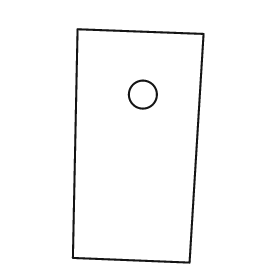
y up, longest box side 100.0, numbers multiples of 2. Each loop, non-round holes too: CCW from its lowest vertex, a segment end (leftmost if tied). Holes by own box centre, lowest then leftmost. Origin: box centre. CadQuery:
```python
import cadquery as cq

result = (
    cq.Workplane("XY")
    .moveTo(22.0, -50.0)
    .lineTo(28.0, 48.0)
    .lineTo(-26.0, 50.0)
    .lineTo(-28.0, -48.0)
    .close()
    .moveTo(2.0, 22.0)
    .circle(6.0)
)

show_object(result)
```